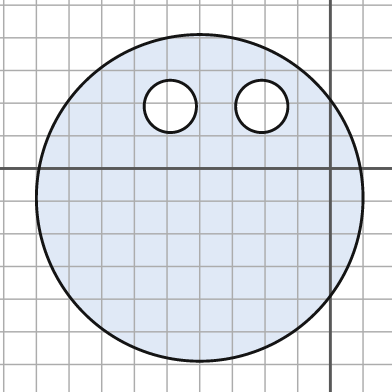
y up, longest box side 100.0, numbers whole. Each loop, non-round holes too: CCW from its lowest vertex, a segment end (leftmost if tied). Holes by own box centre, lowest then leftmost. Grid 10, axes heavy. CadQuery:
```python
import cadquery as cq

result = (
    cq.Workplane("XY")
    .moveTo(-40.0, -9.0)
    .circle(50.0)
    .moveTo(-49.0, 19.0)
    .circle(8.0)
    .moveTo(-21.0, 19.0)
    .circle(8.0)
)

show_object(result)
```